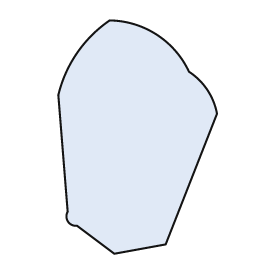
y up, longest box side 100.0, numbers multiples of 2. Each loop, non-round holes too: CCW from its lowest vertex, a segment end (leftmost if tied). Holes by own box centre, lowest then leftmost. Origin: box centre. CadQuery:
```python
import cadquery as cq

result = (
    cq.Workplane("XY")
    .moveTo(-10.0, -50.0)
    .lineTo(12.0, -46.0)
    .lineTo(34.0, 10.0)
    .threePointArc((30.0, 20.0), (22.0, 28.0))
    .threePointArc((8.0, 44.0), (-12.0, 50.0))
    .threePointArc((-26.0, 36.0), (-34.0, 18.0))
    .lineTo(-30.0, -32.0)
    .threePointArc((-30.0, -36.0), (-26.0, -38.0))
    .close()
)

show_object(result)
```